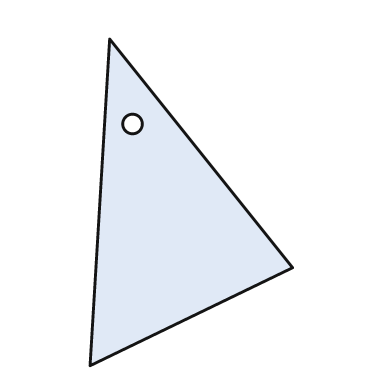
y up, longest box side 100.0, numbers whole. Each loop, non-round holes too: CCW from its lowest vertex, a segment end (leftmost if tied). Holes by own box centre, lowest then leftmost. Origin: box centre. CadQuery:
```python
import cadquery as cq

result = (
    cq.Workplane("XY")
    .moveTo(-31.0, -50.0)
    .lineTo(31.0, -20.0)
    .lineTo(-25.0, 50.0)
    .close()
    .moveTo(-18.0, 24.0)
    .circle(3.0)
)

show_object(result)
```